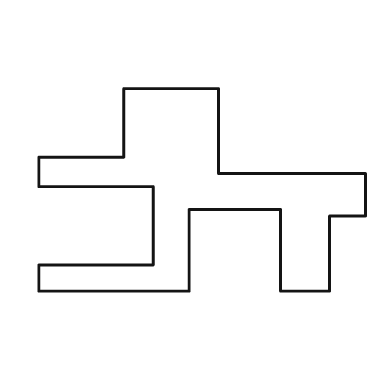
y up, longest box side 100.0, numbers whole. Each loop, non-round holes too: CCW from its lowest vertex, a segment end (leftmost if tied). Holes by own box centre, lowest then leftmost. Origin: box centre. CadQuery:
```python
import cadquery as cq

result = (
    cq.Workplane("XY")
    .moveTo(-50.0, -31.0)
    .lineTo(-4.0, -31.0)
    .lineTo(-4.0, -6.0)
    .lineTo(24.0, -6.0)
    .lineTo(24.0, -31.0)
    .lineTo(39.0, -31.0)
    .lineTo(39.0, -8.0)
    .lineTo(50.0, -8.0)
    .lineTo(50.0, 5.0)
    .lineTo(5.0, 5.0)
    .lineTo(5.0, 31.0)
    .lineTo(-24.0, 31.0)
    .lineTo(-24.0, 10.0)
    .lineTo(-50.0, 10.0)
    .lineTo(-50.0, 1.0)
    .lineTo(-15.0, 1.0)
    .lineTo(-15.0, -23.0)
    .lineTo(-50.0, -23.0)
    .close()
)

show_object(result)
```